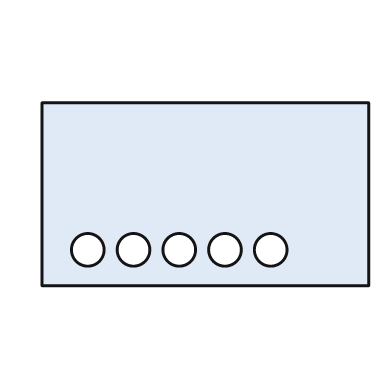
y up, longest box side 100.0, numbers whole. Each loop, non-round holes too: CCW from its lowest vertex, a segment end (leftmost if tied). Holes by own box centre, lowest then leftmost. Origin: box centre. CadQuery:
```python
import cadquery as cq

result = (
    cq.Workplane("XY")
    .moveTo(-50.0, -28.0)
    .lineTo(50.0, -28.0)
    .lineTo(50.0, 28.0)
    .lineTo(-50.0, 28.0)
    .close()
    .moveTo(-36.0, -17.0)
    .circle(5.0)
    .moveTo(-22.0, -17.0)
    .circle(5.0)
    .moveTo(-8.0, -17.0)
    .circle(5.0)
    .moveTo(6.0, -17.0)
    .circle(5.0)
    .moveTo(20.0, -17.0)
    .circle(5.0)
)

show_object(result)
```